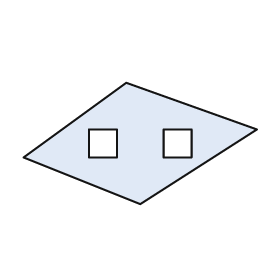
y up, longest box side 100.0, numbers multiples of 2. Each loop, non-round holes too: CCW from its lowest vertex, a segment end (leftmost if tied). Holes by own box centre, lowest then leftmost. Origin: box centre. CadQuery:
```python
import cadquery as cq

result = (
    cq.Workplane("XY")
    .moveTo(0.0, -26.0)
    .lineTo(50.0, 6.0)
    .lineTo(-6.0, 26.0)
    .lineTo(-50.0, -6.0)
    .close()
    .moveTo(-22.0, -6.0)
    .lineTo(-10.0, -6.0)
    .lineTo(-10.0, 6.0)
    .lineTo(-22.0, 6.0)
    .close()
    .moveTo(10.0, -6.0)
    .lineTo(22.0, -6.0)
    .lineTo(22.0, 6.0)
    .lineTo(10.0, 6.0)
    .close()
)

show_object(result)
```